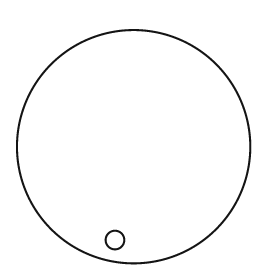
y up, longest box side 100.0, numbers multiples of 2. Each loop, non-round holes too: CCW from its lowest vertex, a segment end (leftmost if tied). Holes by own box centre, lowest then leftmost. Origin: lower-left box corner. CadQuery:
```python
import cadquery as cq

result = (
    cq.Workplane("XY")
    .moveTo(50.0, 50.0)
    .circle(50.0)
    .moveTo(42.0, 10.0)
    .circle(4.0)
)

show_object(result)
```